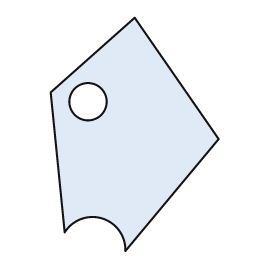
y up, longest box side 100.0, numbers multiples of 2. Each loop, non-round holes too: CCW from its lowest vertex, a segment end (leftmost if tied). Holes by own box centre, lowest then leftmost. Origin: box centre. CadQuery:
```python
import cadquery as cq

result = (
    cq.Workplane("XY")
    .moveTo(-4.0, -50.0)
    .lineTo(36.0, -2.0)
    .lineTo(0.0, 50.0)
    .lineTo(-36.0, 18.0)
    .lineTo(-30.0, -42.0)
    .threePointArc((-14.0, -36.0), (-4.0, -50.0))
    .close()
    .moveTo(-20.0, 14.0)
    .circle(8.0)
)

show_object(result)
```